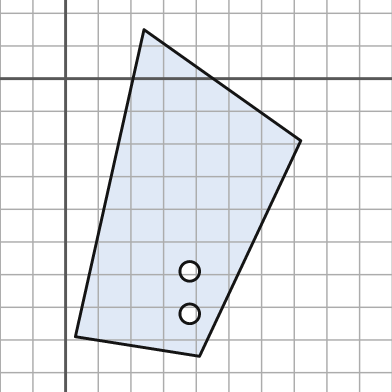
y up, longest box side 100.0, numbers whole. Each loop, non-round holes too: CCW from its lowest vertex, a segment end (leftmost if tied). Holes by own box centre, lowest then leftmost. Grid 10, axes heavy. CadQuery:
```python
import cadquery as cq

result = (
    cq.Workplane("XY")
    .moveTo(41.0, -85.0)
    .lineTo(72.0, -19.0)
    .lineTo(24.0, 15.0)
    .lineTo(3.0, -79.0)
    .close()
    .moveTo(38.0, -72.0)
    .circle(3.0)
    .moveTo(38.0, -59.0)
    .circle(3.0)
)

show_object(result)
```